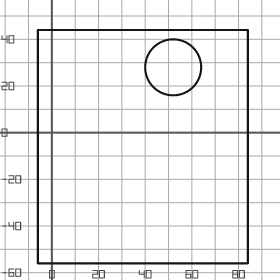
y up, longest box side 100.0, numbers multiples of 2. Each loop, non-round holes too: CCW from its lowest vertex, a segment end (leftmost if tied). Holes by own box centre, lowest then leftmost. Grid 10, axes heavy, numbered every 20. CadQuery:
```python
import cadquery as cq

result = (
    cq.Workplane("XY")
    .moveTo(-6.0, -56.0)
    .lineTo(84.0, -56.0)
    .lineTo(84.0, 44.0)
    .lineTo(-6.0, 44.0)
    .close()
    .moveTo(52.0, 28.0)
    .circle(12.0)
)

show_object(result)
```